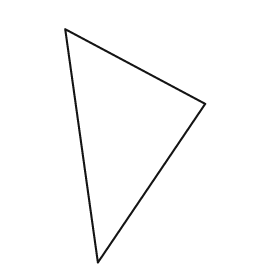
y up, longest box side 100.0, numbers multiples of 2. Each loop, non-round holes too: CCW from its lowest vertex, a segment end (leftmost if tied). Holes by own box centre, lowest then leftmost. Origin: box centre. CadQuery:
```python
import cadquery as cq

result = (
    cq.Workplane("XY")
    .moveTo(-16.0, -50.0)
    .lineTo(30.0, 18.0)
    .lineTo(-30.0, 50.0)
    .close()
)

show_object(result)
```